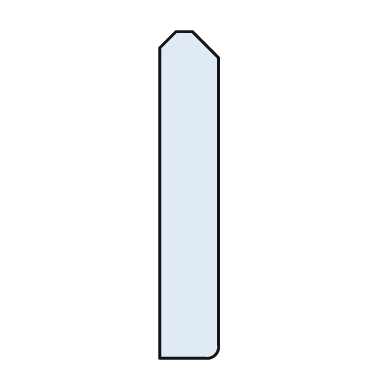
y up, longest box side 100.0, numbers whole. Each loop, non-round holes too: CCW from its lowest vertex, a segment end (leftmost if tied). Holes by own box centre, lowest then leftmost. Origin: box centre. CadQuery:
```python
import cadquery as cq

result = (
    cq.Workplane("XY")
    .moveTo(-9.0, -50.0)
    .lineTo(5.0, -50.0)
    .threePointArc((8.0, -49.0), (9.0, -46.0))
    .lineTo(9.0, 42.0)
    .lineTo(1.0, 50.0)
    .lineTo(-4.0, 50.0)
    .lineTo(-9.0, 45.0)
    .close()
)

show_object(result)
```